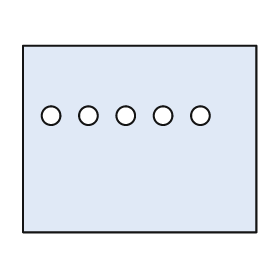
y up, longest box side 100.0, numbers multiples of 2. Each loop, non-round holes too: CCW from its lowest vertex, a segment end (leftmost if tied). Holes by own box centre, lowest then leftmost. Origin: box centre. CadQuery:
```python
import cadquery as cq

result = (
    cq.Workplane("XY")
    .moveTo(-50.0, -40.0)
    .lineTo(50.0, -40.0)
    .lineTo(50.0, 40.0)
    .lineTo(-50.0, 40.0)
    .close()
    .moveTo(-38.0, 10.0)
    .circle(4.0)
    .moveTo(-22.0, 10.0)
    .circle(4.0)
    .moveTo(-6.0, 10.0)
    .circle(4.0)
    .moveTo(10.0, 10.0)
    .circle(4.0)
    .moveTo(26.0, 10.0)
    .circle(4.0)
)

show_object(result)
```